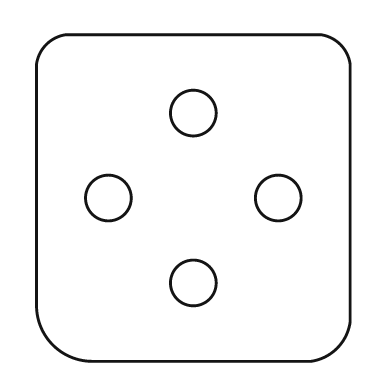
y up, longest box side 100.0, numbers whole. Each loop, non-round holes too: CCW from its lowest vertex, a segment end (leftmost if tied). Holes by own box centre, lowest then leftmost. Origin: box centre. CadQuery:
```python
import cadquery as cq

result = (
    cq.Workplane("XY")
    .moveTo(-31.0, -50.0)
    .lineTo(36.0, -50.0)
    .threePointArc((44.0, -46.0), (48.0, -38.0))
    .lineTo(48.0, 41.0)
    .threePointArc((45.0, 47.0), (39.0, 50.0))
    .lineTo(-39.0, 50.0)
    .threePointArc((-45.0, 47.0), (-48.0, 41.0))
    .lineTo(-48.0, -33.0)
    .threePointArc((-43.0, -45.0), (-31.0, -50.0))
    .close()
    .moveTo(0.0, -26.0)
    .circle(7.0)
    .moveTo(-26.0, 0.0)
    .circle(7.0)
    .moveTo(26.0, 0.0)
    .circle(7.0)
    .moveTo(0.0, 26.0)
    .circle(7.0)
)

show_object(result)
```